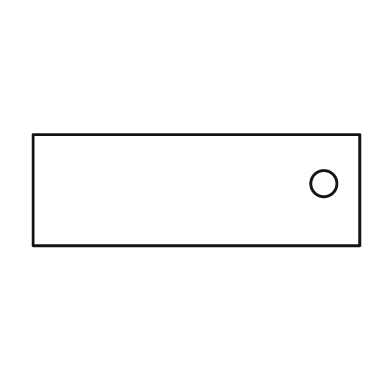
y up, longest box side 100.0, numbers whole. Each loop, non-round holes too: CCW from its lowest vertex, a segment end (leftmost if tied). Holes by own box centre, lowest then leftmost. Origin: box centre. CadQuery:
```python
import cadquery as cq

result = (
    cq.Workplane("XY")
    .moveTo(-50.0, -17.0)
    .lineTo(50.0, -17.0)
    .lineTo(50.0, 17.0)
    .lineTo(-50.0, 17.0)
    .close()
    .moveTo(39.0, 2.0)
    .circle(4.0)
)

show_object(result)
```